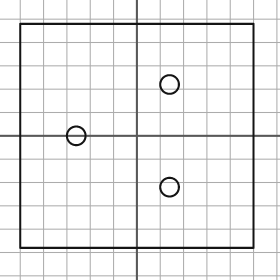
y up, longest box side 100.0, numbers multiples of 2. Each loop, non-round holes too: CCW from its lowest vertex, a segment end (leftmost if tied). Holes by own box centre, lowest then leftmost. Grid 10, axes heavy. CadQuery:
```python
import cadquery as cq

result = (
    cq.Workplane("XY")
    .moveTo(-50.0, -48.0)
    .lineTo(50.0, -48.0)
    .lineTo(50.0, 48.0)
    .lineTo(-50.0, 48.0)
    .close()
    .moveTo(14.0, -22.0)
    .circle(4.0)
    .moveTo(-26.0, 0.0)
    .circle(4.0)
    .moveTo(14.0, 22.0)
    .circle(4.0)
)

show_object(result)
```